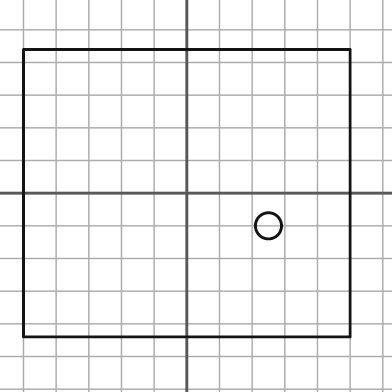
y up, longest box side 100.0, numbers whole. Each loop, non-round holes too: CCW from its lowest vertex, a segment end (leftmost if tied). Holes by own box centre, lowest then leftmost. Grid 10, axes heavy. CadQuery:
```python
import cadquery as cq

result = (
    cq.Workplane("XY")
    .moveTo(-50.0, -44.0)
    .lineTo(50.0, -44.0)
    .lineTo(50.0, 44.0)
    .lineTo(-50.0, 44.0)
    .close()
    .moveTo(25.0, -10.0)
    .circle(4.0)
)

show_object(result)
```